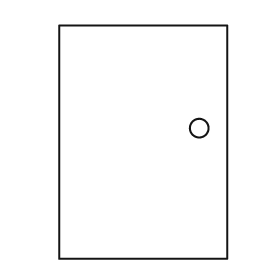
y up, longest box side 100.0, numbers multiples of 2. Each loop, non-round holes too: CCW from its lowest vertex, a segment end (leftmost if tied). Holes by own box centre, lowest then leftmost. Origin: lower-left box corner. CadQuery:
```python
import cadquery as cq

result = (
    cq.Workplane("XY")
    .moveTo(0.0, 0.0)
    .lineTo(72.0, 0.0)
    .lineTo(72.0, 100.0)
    .lineTo(0.0, 100.0)
    .close()
    .moveTo(60.0, 56.0)
    .circle(4.0)
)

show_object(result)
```